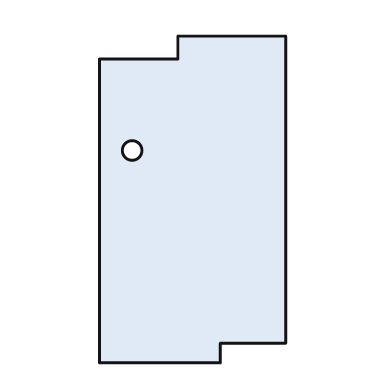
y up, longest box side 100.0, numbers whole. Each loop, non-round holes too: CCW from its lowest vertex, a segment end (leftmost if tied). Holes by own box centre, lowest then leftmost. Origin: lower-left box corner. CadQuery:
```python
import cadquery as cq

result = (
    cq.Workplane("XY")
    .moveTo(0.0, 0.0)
    .lineTo(37.0, 0.0)
    .lineTo(37.0, 6.0)
    .lineTo(57.0, 6.0)
    .lineTo(57.0, 100.0)
    .lineTo(24.0, 100.0)
    .lineTo(24.0, 93.0)
    .lineTo(0.0, 93.0)
    .close()
    .moveTo(10.0, 65.0)
    .circle(3.0)
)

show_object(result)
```